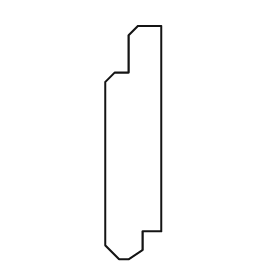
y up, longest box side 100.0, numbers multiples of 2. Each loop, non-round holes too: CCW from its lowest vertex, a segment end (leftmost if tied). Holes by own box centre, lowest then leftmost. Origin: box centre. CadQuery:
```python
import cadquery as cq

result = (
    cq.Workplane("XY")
    .moveTo(-6.0, -50.0)
    .lineTo(-2.0, -50.0)
    .lineTo(4.0, -46.0)
    .lineTo(4.0, -38.0)
    .lineTo(12.0, -38.0)
    .lineTo(12.0, 50.0)
    .lineTo(2.0, 50.0)
    .lineTo(-2.0, 46.0)
    .lineTo(-2.0, 30.0)
    .lineTo(-8.0, 30.0)
    .lineTo(-12.0, 26.0)
    .lineTo(-12.0, -44.0)
    .close()
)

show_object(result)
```